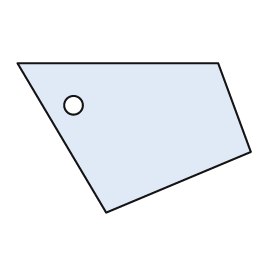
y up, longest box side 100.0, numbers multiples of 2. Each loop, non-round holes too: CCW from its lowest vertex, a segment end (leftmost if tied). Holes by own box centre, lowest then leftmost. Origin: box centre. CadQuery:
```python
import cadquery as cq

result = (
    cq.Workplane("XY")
    .moveTo(-12.0, -32.0)
    .lineTo(50.0, -6.0)
    .lineTo(36.0, 32.0)
    .lineTo(-50.0, 32.0)
    .close()
    .moveTo(-26.0, 14.0)
    .circle(4.0)
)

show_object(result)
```